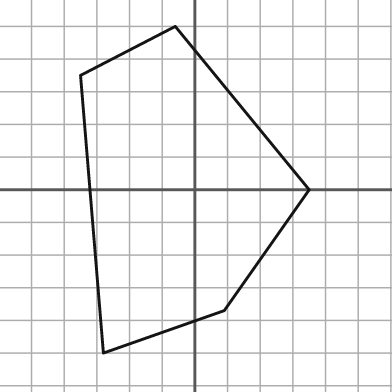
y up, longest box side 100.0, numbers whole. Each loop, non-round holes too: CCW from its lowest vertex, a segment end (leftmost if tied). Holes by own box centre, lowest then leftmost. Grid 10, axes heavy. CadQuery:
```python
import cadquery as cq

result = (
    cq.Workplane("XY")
    .moveTo(-28.0, -50.0)
    .lineTo(9.0, -37.0)
    .lineTo(35.0, 0.0)
    .lineTo(-6.0, 50.0)
    .lineTo(-35.0, 35.0)
    .close()
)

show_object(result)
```